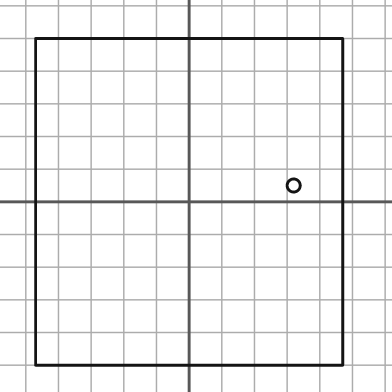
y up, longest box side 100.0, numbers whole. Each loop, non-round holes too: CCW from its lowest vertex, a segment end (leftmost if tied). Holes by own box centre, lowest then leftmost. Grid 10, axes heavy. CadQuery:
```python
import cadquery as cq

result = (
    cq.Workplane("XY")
    .moveTo(-47.0, -50.0)
    .lineTo(47.0, -50.0)
    .lineTo(47.0, 50.0)
    .lineTo(-47.0, 50.0)
    .close()
    .moveTo(32.0, 5.0)
    .circle(2.0)
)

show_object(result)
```